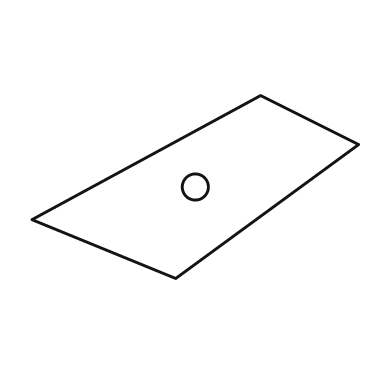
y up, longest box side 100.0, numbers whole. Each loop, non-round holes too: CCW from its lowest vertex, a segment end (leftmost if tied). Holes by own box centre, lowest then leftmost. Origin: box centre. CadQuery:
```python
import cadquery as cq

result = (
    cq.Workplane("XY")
    .moveTo(-6.0, -28.0)
    .lineTo(50.0, 13.0)
    .lineTo(20.0, 28.0)
    .lineTo(-50.0, -10.0)
    .close()
    .moveTo(0.0, 0.0)
    .circle(4.0)
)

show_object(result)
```